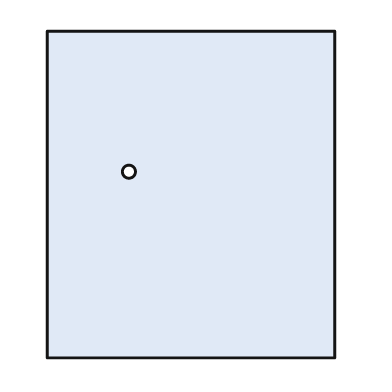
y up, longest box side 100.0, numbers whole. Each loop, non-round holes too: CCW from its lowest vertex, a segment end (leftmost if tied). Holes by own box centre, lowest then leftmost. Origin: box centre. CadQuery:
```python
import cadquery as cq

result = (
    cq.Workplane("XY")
    .moveTo(-44.0, -50.0)
    .lineTo(44.0, -50.0)
    .lineTo(44.0, 50.0)
    .lineTo(-44.0, 50.0)
    .close()
    .moveTo(-19.0, 7.0)
    .circle(2.0)
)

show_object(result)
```